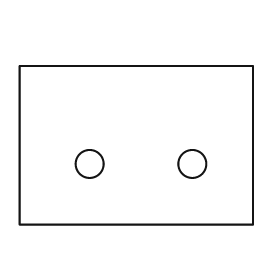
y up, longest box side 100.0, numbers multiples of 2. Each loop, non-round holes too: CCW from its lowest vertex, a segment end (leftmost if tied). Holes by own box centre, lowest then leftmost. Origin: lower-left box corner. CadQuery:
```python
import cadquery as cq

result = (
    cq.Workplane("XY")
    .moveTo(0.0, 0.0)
    .lineTo(100.0, 0.0)
    .lineTo(100.0, 68.0)
    .lineTo(0.0, 68.0)
    .close()
    .moveTo(30.0, 26.0)
    .circle(6.0)
    .moveTo(74.0, 26.0)
    .circle(6.0)
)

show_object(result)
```